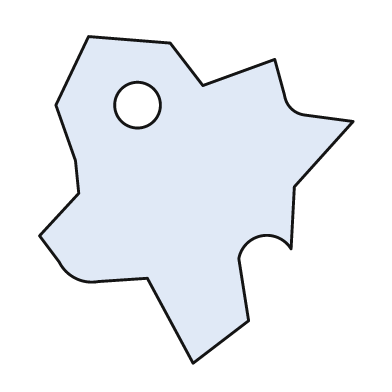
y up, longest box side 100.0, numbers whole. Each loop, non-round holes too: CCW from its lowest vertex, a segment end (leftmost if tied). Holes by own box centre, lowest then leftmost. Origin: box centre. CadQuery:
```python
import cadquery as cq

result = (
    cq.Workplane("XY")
    .moveTo(-1.0, -50.0)
    .lineTo(16.0, -37.0)
    .lineTo(13.0, -18.0)
    .threePointArc((20.0, -11.0), (29.0, -15.0))
    .lineTo(30.0, 4.0)
    .lineTo(48.0, 24.0)
    .lineTo(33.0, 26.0)
    .threePointArc((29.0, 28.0), (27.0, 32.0))
    .lineTo(24.0, 43.0)
    .lineTo(2.0, 35.0)
    .lineTo(-8.0, 48.0)
    .lineTo(-33.0, 50.0)
    .lineTo(-43.0, 29.0)
    .lineTo(-37.0, 12.0)
    .lineTo(-36.0, 2.0)
    .lineTo(-48.0, -11.0)
    .lineTo(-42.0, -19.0)
    .threePointArc((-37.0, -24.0), (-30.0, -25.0))
    .lineTo(-15.0, -24.0)
    .close()
    .moveTo(-18.0, 29.0)
    .circle(7.0)
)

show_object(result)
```